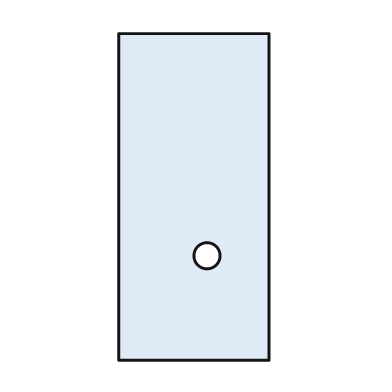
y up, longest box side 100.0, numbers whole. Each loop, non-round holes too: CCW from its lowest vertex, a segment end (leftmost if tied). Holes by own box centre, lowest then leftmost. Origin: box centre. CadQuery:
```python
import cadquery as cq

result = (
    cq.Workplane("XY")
    .moveTo(-23.0, -50.0)
    .lineTo(23.0, -50.0)
    .lineTo(23.0, 50.0)
    .lineTo(-23.0, 50.0)
    .close()
    .moveTo(4.0, -18.0)
    .circle(4.0)
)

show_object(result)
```